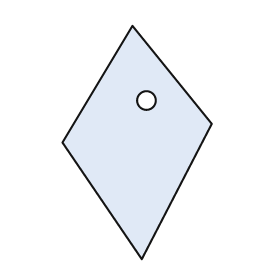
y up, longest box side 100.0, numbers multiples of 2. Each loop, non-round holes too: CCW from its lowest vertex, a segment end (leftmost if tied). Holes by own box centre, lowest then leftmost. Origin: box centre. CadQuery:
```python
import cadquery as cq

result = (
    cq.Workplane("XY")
    .moveTo(2.0, -50.0)
    .lineTo(32.0, 8.0)
    .lineTo(-2.0, 50.0)
    .lineTo(-32.0, 0.0)
    .close()
    .moveTo(4.0, 18.0)
    .circle(4.0)
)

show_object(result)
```